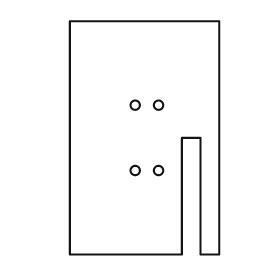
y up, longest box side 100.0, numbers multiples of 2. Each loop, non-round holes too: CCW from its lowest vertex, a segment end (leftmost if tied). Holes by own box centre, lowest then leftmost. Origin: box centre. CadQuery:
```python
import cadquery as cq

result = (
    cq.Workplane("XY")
    .moveTo(-32.0, -50.0)
    .lineTo(16.0, -50.0)
    .lineTo(16.0, 0.0)
    .lineTo(24.0, 0.0)
    .lineTo(24.0, -50.0)
    .lineTo(32.0, -50.0)
    .lineTo(32.0, 50.0)
    .lineTo(-32.0, 50.0)
    .close()
    .moveTo(-4.0, -14.0)
    .circle(2.0)
    .moveTo(6.0, -14.0)
    .circle(2.0)
    .moveTo(-4.0, 14.0)
    .circle(2.0)
    .moveTo(6.0, 14.0)
    .circle(2.0)
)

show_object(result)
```